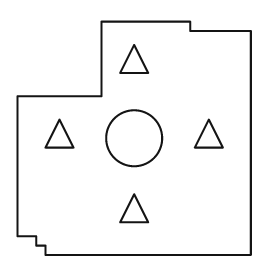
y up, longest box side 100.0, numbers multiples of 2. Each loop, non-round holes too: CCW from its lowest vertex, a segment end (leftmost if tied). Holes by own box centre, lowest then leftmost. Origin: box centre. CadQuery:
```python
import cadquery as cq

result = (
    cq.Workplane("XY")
    .moveTo(-38.0, -50.0)
    .lineTo(50.0, -50.0)
    .lineTo(50.0, 46.0)
    .lineTo(24.0, 46.0)
    .lineTo(24.0, 50.0)
    .lineTo(-14.0, 50.0)
    .lineTo(-14.0, 18.0)
    .lineTo(-50.0, 18.0)
    .lineTo(-50.0, -42.0)
    .lineTo(-42.0, -42.0)
    .lineTo(-42.0, -46.0)
    .lineTo(-38.0, -46.0)
    .close()
    .moveTo(-6.0, -36.0)
    .lineTo(6.0, -36.0)
    .lineTo(0.0, -24.0)
    .close()
    .moveTo(0.0, 0.0)
    .circle(12.0)
    .moveTo(-38.0, -4.0)
    .lineTo(-26.0, -4.0)
    .lineTo(-32.0, 8.0)
    .close()
    .moveTo(26.0, -4.0)
    .lineTo(38.0, -4.0)
    .lineTo(32.0, 8.0)
    .close()
    .moveTo(-6.0, 28.0)
    .lineTo(6.0, 28.0)
    .lineTo(0.0, 40.0)
    .close()
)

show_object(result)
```